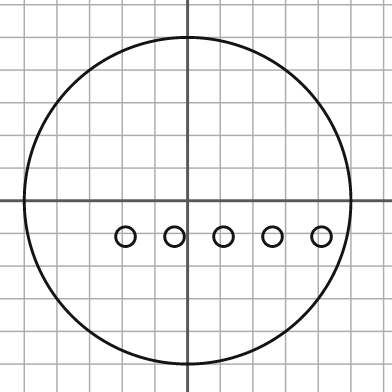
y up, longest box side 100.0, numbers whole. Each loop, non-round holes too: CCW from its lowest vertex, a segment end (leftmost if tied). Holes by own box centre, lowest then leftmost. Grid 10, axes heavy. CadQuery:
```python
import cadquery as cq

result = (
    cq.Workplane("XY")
    .moveTo(0.0, 0.0)
    .circle(50.0)
    .moveTo(-19.0, -11.0)
    .circle(3.0)
    .moveTo(-4.0, -11.0)
    .circle(3.0)
    .moveTo(11.0, -11.0)
    .circle(3.0)
    .moveTo(26.0, -11.0)
    .circle(3.0)
    .moveTo(41.0, -11.0)
    .circle(3.0)
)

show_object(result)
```